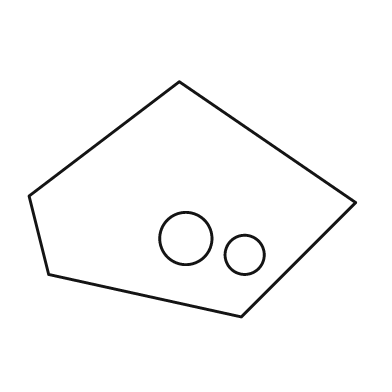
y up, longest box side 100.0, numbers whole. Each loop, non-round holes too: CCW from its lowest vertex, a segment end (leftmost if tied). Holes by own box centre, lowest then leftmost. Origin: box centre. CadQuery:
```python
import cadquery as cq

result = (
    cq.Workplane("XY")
    .moveTo(15.0, -36.0)
    .lineTo(50.0, -1.0)
    .lineTo(-4.0, 36.0)
    .lineTo(-50.0, 1.0)
    .lineTo(-44.0, -23.0)
    .close()
    .moveTo(16.0, -17.0)
    .circle(6.0)
    .moveTo(-2.0, -12.0)
    .circle(8.0)
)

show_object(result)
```